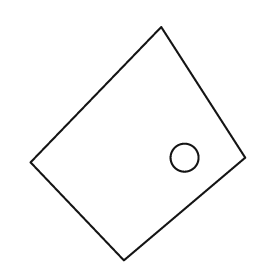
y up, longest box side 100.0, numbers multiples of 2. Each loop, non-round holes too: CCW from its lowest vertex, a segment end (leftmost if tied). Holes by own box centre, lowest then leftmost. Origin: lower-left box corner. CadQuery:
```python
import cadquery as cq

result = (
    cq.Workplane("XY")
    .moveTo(40.0, 0.0)
    .lineTo(92.0, 44.0)
    .lineTo(56.0, 100.0)
    .lineTo(0.0, 42.0)
    .close()
    .moveTo(66.0, 44.0)
    .circle(6.0)
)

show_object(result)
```